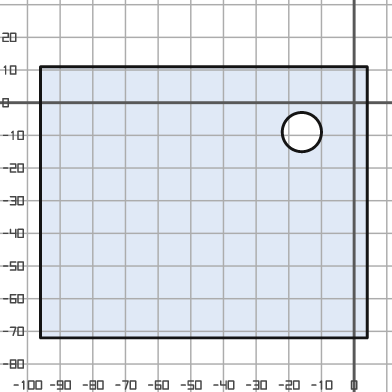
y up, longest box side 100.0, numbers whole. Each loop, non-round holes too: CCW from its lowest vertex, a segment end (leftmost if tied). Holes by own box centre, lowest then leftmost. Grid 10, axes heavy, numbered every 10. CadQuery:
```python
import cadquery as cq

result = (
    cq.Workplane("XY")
    .moveTo(-96.0, -72.0)
    .lineTo(4.0, -72.0)
    .lineTo(4.0, 11.0)
    .lineTo(-96.0, 11.0)
    .close()
    .moveTo(-16.0, -9.0)
    .circle(6.0)
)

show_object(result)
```